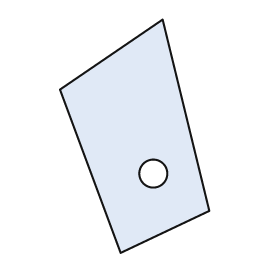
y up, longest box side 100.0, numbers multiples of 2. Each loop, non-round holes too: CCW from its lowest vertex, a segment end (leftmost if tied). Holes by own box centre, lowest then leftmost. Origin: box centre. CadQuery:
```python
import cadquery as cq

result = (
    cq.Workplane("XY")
    .moveTo(-6.0, -50.0)
    .lineTo(32.0, -32.0)
    .lineTo(12.0, 50.0)
    .lineTo(-32.0, 20.0)
    .close()
    .moveTo(8.0, -16.0)
    .circle(6.0)
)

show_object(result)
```